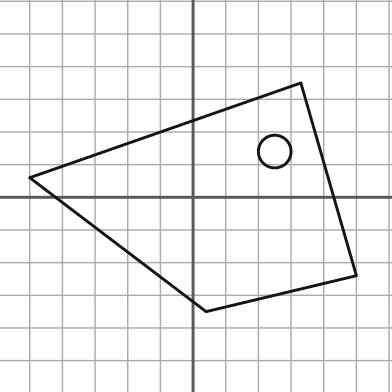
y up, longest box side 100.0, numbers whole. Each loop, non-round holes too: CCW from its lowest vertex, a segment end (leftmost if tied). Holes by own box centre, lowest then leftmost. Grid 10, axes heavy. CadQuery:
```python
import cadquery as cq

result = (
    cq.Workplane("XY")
    .moveTo(4.0, -35.0)
    .lineTo(50.0, -24.0)
    .lineTo(33.0, 35.0)
    .lineTo(-50.0, 6.0)
    .close()
    .moveTo(25.0, 14.0)
    .circle(5.0)
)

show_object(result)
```